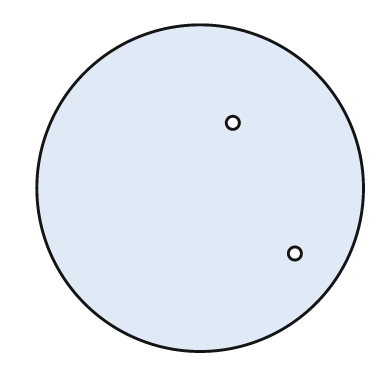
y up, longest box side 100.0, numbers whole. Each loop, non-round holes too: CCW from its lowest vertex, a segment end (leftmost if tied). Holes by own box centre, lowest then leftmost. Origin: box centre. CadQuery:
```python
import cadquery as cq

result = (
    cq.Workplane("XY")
    .moveTo(0.0, 0.0)
    .circle(50.0)
    .moveTo(29.0, -20.0)
    .circle(2.0)
    .moveTo(10.0, 20.0)
    .circle(2.0)
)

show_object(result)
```